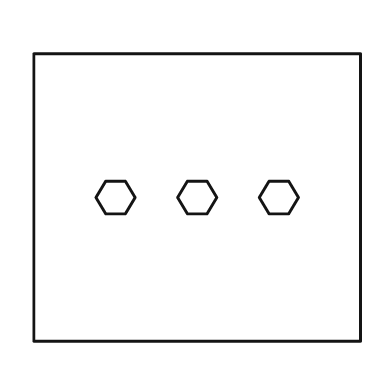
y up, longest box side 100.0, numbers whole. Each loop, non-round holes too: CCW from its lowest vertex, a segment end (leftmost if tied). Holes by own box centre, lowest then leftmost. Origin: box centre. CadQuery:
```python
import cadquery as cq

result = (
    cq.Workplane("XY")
    .moveTo(-50.0, -44.0)
    .lineTo(50.0, -44.0)
    .lineTo(50.0, 44.0)
    .lineTo(-50.0, 44.0)
    .close()
    .moveTo(-28.0, -5.0)
    .lineTo(-22.0, -5.0)
    .lineTo(-19.0, 0.0)
    .lineTo(-22.0, 5.0)
    .lineTo(-28.0, 5.0)
    .lineTo(-31.0, 0.0)
    .close()
    .moveTo(-3.0, -5.0)
    .lineTo(3.0, -5.0)
    .lineTo(6.0, 0.0)
    .lineTo(3.0, 5.0)
    .lineTo(-3.0, 5.0)
    .lineTo(-6.0, 0.0)
    .close()
    .moveTo(22.0, -5.0)
    .lineTo(28.0, -5.0)
    .lineTo(31.0, 0.0)
    .lineTo(28.0, 5.0)
    .lineTo(22.0, 5.0)
    .lineTo(19.0, 0.0)
    .close()
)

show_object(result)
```